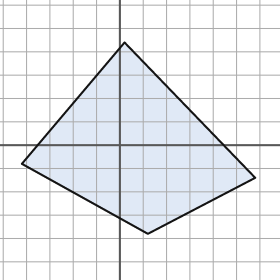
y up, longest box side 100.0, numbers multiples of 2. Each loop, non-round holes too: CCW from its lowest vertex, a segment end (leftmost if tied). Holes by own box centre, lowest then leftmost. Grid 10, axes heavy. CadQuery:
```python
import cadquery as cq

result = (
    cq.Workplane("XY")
    .moveTo(12.0, -38.0)
    .lineTo(58.0, -14.0)
    .lineTo(2.0, 44.0)
    .lineTo(-42.0, -8.0)
    .close()
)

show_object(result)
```